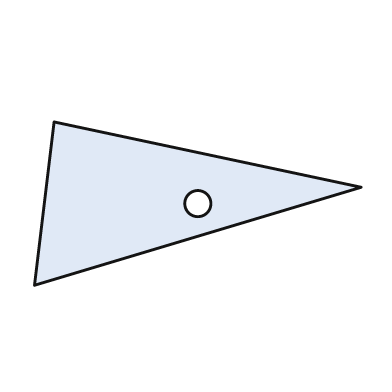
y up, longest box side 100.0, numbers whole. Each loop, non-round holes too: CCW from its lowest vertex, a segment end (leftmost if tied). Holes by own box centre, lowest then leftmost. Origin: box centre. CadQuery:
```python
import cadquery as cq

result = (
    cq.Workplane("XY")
    .moveTo(-50.0, -25.0)
    .lineTo(50.0, 5.0)
    .lineTo(-44.0, 25.0)
    .close()
    .moveTo(0.0, 0.0)
    .circle(4.0)
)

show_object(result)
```